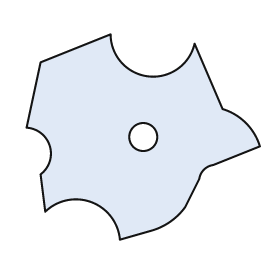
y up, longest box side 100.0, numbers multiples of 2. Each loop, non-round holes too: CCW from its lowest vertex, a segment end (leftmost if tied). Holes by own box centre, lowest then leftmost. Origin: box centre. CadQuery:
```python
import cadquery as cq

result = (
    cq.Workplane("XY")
    .moveTo(-10.0, -44.0)
    .lineTo(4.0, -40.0)
    .threePointArc((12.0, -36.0), (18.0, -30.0))
    .lineTo(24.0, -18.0)
    .threePointArc((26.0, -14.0), (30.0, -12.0))
    .lineTo(50.0, -4.0)
    .threePointArc((44.0, 6.0), (34.0, 12.0))
    .lineTo(22.0, 40.0)
    .threePointArc((2.0, 26.0), (-14.0, 44.0))
    .lineTo(-44.0, 32.0)
    .lineTo(-50.0, 4.0)
    .threePointArc((-40.0, -4.0), (-44.0, -16.0))
    .lineTo(-42.0, -32.0)
    .threePointArc((-22.0, -28.0), (-10.0, -44.0))
    .close()
    .moveTo(0.0, 0.0)
    .circle(6.0)
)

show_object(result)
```